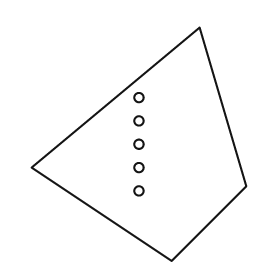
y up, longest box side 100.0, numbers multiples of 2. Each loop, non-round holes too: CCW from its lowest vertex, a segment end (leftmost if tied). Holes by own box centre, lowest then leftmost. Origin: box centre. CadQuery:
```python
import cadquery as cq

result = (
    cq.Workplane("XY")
    .moveTo(14.0, -50.0)
    .lineTo(46.0, -18.0)
    .lineTo(26.0, 50.0)
    .lineTo(-46.0, -10.0)
    .close()
    .moveTo(0.0, -20.0)
    .circle(2.0)
    .moveTo(0.0, -10.0)
    .circle(2.0)
    .moveTo(0.0, 0.0)
    .circle(2.0)
    .moveTo(0.0, 10.0)
    .circle(2.0)
    .moveTo(0.0, 20.0)
    .circle(2.0)
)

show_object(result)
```